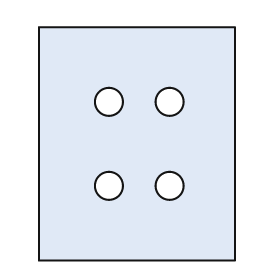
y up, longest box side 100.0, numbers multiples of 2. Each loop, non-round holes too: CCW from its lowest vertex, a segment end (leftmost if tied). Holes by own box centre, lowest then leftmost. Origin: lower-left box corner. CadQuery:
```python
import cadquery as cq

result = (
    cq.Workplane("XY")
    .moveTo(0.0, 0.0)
    .lineTo(84.0, 0.0)
    .lineTo(84.0, 100.0)
    .lineTo(0.0, 100.0)
    .close()
    .moveTo(30.0, 32.0)
    .circle(6.0)
    .moveTo(56.0, 32.0)
    .circle(6.0)
    .moveTo(30.0, 68.0)
    .circle(6.0)
    .moveTo(56.0, 68.0)
    .circle(6.0)
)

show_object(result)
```